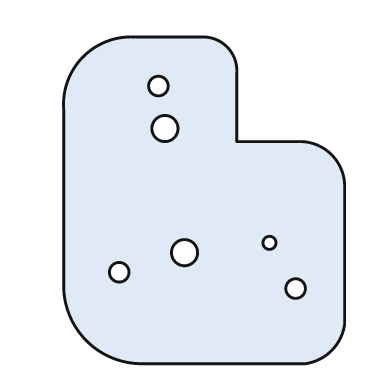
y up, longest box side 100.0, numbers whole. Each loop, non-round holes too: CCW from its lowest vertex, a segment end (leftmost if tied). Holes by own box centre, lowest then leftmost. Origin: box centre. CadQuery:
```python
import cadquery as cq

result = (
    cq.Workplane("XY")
    .moveTo(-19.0, -50.0)
    .lineTo(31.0, -50.0)
    .threePointArc((39.0, -46.0), (43.0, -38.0))
    .lineTo(43.0, 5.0)
    .threePointArc((39.0, 14.0), (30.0, 18.0))
    .lineTo(10.0, 18.0)
    .lineTo(10.0, 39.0)
    .threePointArc((7.0, 47.0), (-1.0, 50.0))
    .lineTo(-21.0, 50.0)
    .threePointArc((-37.0, 44.0), (-43.0, 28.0))
    .lineTo(-43.0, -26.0)
    .threePointArc((-36.0, -43.0), (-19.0, -50.0))
    .close()
    .moveTo(28.0, -27.0)
    .circle(3.0)
    .moveTo(-26.0, -22.0)
    .circle(3.0)
    .moveTo(-6.0, -16.0)
    .circle(4.0)
    .moveTo(20.0, -13.0)
    .circle(2.0)
    .moveTo(-12.0, 22.0)
    .circle(4.0)
    .moveTo(-14.0, 35.0)
    .circle(3.0)
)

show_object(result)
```